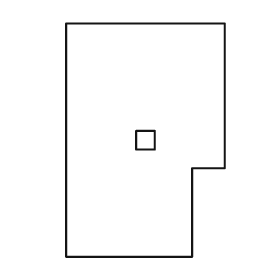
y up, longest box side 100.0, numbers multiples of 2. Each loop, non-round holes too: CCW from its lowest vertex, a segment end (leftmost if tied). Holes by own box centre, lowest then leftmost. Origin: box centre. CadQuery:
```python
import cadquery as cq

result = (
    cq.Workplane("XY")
    .moveTo(-34.0, -50.0)
    .lineTo(20.0, -50.0)
    .lineTo(20.0, -12.0)
    .lineTo(34.0, -12.0)
    .lineTo(34.0, 50.0)
    .lineTo(-34.0, 50.0)
    .close()
    .moveTo(-4.0, -4.0)
    .lineTo(4.0, -4.0)
    .lineTo(4.0, 4.0)
    .lineTo(-4.0, 4.0)
    .close()
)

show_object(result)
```